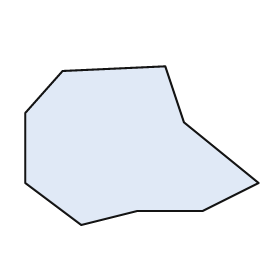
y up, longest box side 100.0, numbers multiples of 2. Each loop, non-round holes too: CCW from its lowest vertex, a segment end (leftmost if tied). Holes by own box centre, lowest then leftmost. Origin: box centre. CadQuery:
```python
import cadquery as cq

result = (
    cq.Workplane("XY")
    .moveTo(-26.0, -34.0)
    .lineTo(-2.0, -28.0)
    .lineTo(26.0, -28.0)
    .lineTo(50.0, -16.0)
    .lineTo(18.0, 10.0)
    .lineTo(10.0, 34.0)
    .lineTo(-34.0, 32.0)
    .lineTo(-50.0, 14.0)
    .lineTo(-50.0, -16.0)
    .close()
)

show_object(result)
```